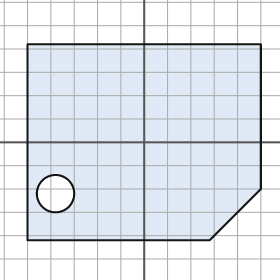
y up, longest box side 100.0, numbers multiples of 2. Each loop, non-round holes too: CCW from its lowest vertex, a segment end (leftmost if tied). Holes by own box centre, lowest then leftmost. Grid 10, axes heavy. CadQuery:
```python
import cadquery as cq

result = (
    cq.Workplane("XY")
    .moveTo(-50.0, -42.0)
    .lineTo(28.0, -42.0)
    .lineTo(50.0, -20.0)
    .lineTo(50.0, 42.0)
    .lineTo(-50.0, 42.0)
    .close()
    .moveTo(-38.0, -22.0)
    .circle(8.0)
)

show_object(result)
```